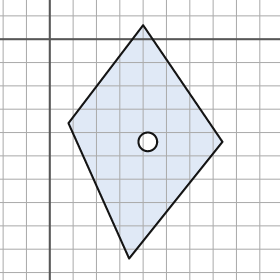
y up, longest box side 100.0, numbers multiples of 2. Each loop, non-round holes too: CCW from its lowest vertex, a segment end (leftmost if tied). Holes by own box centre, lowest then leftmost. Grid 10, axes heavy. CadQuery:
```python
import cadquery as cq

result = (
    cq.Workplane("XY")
    .moveTo(34.0, -94.0)
    .lineTo(74.0, -44.0)
    .lineTo(40.0, 6.0)
    .lineTo(8.0, -36.0)
    .close()
    .moveTo(42.0, -44.0)
    .circle(4.0)
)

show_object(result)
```